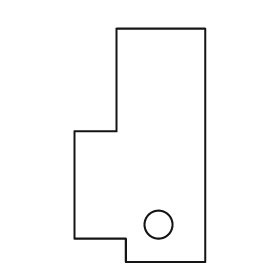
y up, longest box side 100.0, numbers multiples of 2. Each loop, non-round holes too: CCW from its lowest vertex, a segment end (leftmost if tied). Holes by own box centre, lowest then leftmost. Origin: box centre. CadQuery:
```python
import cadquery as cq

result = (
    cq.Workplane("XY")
    .moveTo(-6.0, -50.0)
    .lineTo(28.0, -50.0)
    .lineTo(28.0, 50.0)
    .lineTo(-10.0, 50.0)
    .lineTo(-10.0, 6.0)
    .lineTo(-28.0, 6.0)
    .lineTo(-28.0, -40.0)
    .lineTo(-6.0, -40.0)
    .close()
    .moveTo(8.0, -34.0)
    .circle(6.0)
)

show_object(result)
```